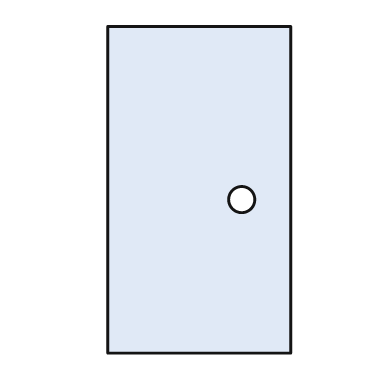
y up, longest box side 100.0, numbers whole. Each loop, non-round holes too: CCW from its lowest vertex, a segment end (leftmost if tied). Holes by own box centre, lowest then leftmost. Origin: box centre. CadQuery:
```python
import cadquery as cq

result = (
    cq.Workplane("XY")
    .moveTo(-28.0, -50.0)
    .lineTo(28.0, -50.0)
    .lineTo(28.0, 50.0)
    .lineTo(-28.0, 50.0)
    .close()
    .moveTo(13.0, -3.0)
    .circle(4.0)
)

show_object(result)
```